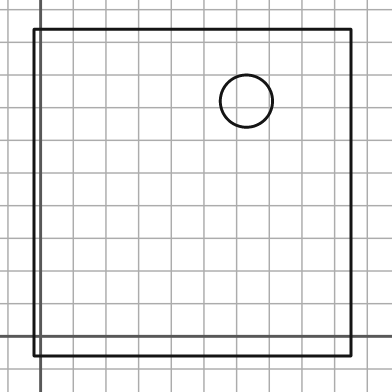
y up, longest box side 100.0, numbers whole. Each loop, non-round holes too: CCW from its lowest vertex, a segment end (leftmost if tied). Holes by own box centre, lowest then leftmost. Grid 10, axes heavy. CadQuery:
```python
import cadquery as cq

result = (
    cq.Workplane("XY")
    .moveTo(-2.0, -6.0)
    .lineTo(95.0, -6.0)
    .lineTo(95.0, 94.0)
    .lineTo(-2.0, 94.0)
    .close()
    .moveTo(63.0, 72.0)
    .circle(8.0)
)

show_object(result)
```